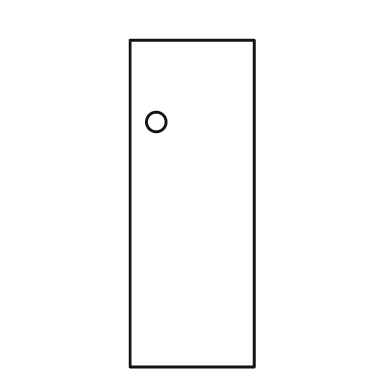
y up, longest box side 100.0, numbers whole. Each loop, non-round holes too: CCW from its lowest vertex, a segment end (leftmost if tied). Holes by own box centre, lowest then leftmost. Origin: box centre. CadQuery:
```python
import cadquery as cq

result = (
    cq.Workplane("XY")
    .moveTo(-19.0, -50.0)
    .lineTo(19.0, -50.0)
    .lineTo(19.0, 50.0)
    .lineTo(-19.0, 50.0)
    .close()
    .moveTo(-11.0, 25.0)
    .circle(3.0)
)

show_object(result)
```